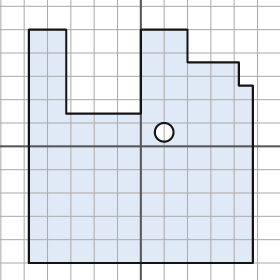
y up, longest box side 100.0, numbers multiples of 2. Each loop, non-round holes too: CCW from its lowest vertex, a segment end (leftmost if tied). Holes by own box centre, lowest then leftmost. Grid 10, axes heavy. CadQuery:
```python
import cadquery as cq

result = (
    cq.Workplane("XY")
    .moveTo(-48.0, -50.0)
    .lineTo(48.0, -50.0)
    .lineTo(48.0, 26.0)
    .lineTo(42.0, 26.0)
    .lineTo(42.0, 36.0)
    .lineTo(20.0, 36.0)
    .lineTo(20.0, 50.0)
    .lineTo(0.0, 50.0)
    .lineTo(0.0, 14.0)
    .lineTo(-32.0, 14.0)
    .lineTo(-32.0, 50.0)
    .lineTo(-48.0, 50.0)
    .close()
    .moveTo(10.0, 6.0)
    .circle(4.0)
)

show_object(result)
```